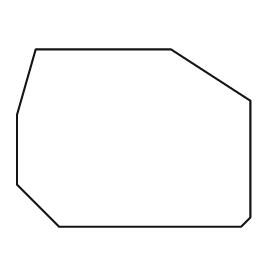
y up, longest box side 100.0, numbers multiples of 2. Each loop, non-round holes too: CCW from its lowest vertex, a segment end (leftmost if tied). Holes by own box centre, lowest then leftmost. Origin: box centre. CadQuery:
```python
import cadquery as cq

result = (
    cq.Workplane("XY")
    .moveTo(-32.0, -38.0)
    .lineTo(46.0, -38.0)
    .lineTo(50.0, -34.0)
    .lineTo(50.0, 16.0)
    .lineTo(16.0, 38.0)
    .lineTo(-42.0, 38.0)
    .lineTo(-50.0, 10.0)
    .lineTo(-50.0, -20.0)
    .close()
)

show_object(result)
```